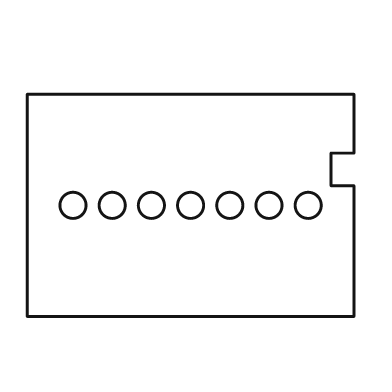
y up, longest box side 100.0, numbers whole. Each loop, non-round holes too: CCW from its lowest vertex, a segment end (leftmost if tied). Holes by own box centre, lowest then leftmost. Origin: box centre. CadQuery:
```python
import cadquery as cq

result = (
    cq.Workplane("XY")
    .moveTo(-50.0, -34.0)
    .lineTo(50.0, -34.0)
    .lineTo(50.0, 6.0)
    .lineTo(43.0, 6.0)
    .lineTo(43.0, 16.0)
    .lineTo(50.0, 16.0)
    .lineTo(50.0, 34.0)
    .lineTo(-50.0, 34.0)
    .close()
    .moveTo(-36.0, 0.0)
    .circle(4.0)
    .moveTo(-24.0, 0.0)
    .circle(4.0)
    .moveTo(-12.0, 0.0)
    .circle(4.0)
    .moveTo(0.0, 0.0)
    .circle(4.0)
    .moveTo(12.0, 0.0)
    .circle(4.0)
    .moveTo(24.0, 0.0)
    .circle(4.0)
    .moveTo(36.0, 0.0)
    .circle(4.0)
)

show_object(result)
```